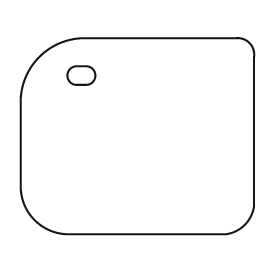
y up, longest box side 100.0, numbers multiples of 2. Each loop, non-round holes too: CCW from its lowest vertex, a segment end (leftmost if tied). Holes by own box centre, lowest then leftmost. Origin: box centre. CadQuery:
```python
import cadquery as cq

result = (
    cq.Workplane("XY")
    .moveTo(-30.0, -42.0)
    .lineTo(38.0, -42.0)
    .threePointArc((46.0, -38.0), (50.0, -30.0))
    .lineTo(50.0, 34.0)
    .threePointArc((48.0, 40.0), (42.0, 42.0))
    .lineTo(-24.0, 42.0)
    .threePointArc((-42.0, 34.0), (-50.0, 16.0))
    .lineTo(-50.0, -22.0)
    .threePointArc((-44.0, -36.0), (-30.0, -42.0))
    .close()
    .moveTo(-26.0, 22.0)
    .lineTo(-22.0, 22.0)
    .threePointArc((-18.0, 26.0), (-22.0, 30.0))
    .lineTo(-26.0, 30.0)
    .threePointArc((-30.0, 26.0), (-26.0, 22.0))
    .close()
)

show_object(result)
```